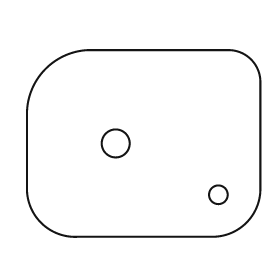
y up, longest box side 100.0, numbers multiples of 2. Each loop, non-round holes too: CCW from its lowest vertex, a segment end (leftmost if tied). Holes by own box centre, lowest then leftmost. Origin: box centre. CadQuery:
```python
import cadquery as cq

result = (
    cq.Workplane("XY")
    .moveTo(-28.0, -40.0)
    .lineTo(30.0, -40.0)
    .threePointArc((44.0, -34.0), (50.0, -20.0))
    .lineTo(50.0, 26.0)
    .threePointArc((46.0, 36.0), (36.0, 40.0))
    .lineTo(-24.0, 40.0)
    .threePointArc((-42.0, 32.0), (-50.0, 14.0))
    .lineTo(-50.0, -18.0)
    .threePointArc((-44.0, -34.0), (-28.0, -40.0))
    .close()
    .moveTo(32.0, -22.0)
    .circle(4.0)
    .moveTo(-12.0, 0.0)
    .circle(6.0)
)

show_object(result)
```